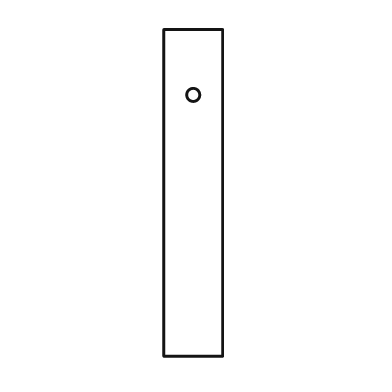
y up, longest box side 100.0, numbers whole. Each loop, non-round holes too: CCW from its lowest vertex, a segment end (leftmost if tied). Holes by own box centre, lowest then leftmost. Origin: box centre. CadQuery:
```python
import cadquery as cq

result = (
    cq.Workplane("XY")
    .moveTo(-9.0, -50.0)
    .lineTo(9.0, -50.0)
    .lineTo(9.0, 50.0)
    .lineTo(-9.0, 50.0)
    .close()
    .moveTo(0.0, 30.0)
    .circle(2.0)
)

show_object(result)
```